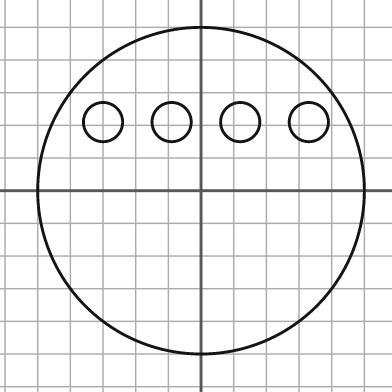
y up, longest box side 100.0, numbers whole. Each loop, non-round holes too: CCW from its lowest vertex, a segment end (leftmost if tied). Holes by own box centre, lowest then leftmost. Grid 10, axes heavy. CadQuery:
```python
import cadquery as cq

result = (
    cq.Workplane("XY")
    .moveTo(0.0, 0.0)
    .circle(50.0)
    .moveTo(-30.0, 21.0)
    .circle(6.0)
    .moveTo(-9.0, 21.0)
    .circle(6.0)
    .moveTo(12.0, 21.0)
    .circle(6.0)
    .moveTo(33.0, 21.0)
    .circle(6.0)
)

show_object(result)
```